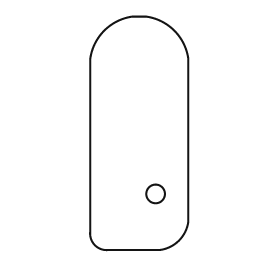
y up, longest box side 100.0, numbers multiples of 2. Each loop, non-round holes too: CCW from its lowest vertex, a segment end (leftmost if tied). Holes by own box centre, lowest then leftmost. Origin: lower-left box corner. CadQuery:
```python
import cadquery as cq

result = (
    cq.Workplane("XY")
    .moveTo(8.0, 0.0)
    .lineTo(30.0, 0.0)
    .threePointArc((38.0, 4.0), (42.0, 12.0))
    .lineTo(42.0, 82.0)
    .threePointArc((36.0, 94.0), (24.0, 100.0))
    .lineTo(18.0, 100.0)
    .threePointArc((6.0, 94.0), (0.0, 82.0))
    .lineTo(0.0, 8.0)
    .threePointArc((2.0, 2.0), (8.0, 0.0))
    .close()
    .moveTo(28.0, 24.0)
    .circle(4.0)
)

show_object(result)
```